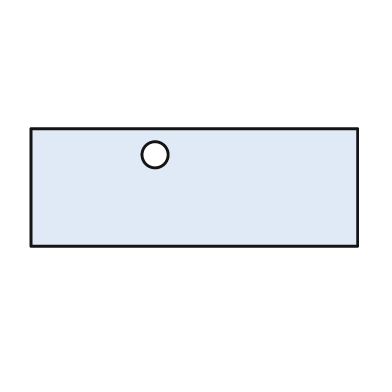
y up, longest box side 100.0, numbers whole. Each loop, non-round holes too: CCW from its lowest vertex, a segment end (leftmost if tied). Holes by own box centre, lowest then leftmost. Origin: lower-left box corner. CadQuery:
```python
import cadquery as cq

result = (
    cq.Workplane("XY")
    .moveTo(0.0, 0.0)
    .lineTo(100.0, 0.0)
    .lineTo(100.0, 36.0)
    .lineTo(0.0, 36.0)
    .close()
    .moveTo(38.0, 28.0)
    .circle(4.0)
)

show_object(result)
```